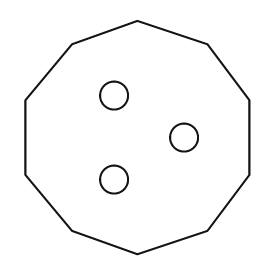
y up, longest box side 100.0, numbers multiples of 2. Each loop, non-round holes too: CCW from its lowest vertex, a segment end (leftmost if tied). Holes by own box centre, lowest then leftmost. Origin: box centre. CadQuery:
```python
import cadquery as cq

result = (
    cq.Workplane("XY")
    .moveTo(0.0, -50.0)
    .lineTo(30.0, -40.0)
    .lineTo(48.0, -16.0)
    .lineTo(48.0, 16.0)
    .lineTo(30.0, 40.0)
    .lineTo(0.0, 50.0)
    .lineTo(-28.0, 40.0)
    .lineTo(-48.0, 16.0)
    .lineTo(-48.0, -16.0)
    .lineTo(-28.0, -40.0)
    .close()
    .moveTo(-10.0, -18.0)
    .circle(6.0)
    .moveTo(20.0, 0.0)
    .circle(6.0)
    .moveTo(-10.0, 18.0)
    .circle(6.0)
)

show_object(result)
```